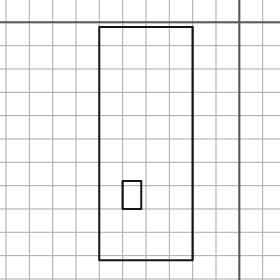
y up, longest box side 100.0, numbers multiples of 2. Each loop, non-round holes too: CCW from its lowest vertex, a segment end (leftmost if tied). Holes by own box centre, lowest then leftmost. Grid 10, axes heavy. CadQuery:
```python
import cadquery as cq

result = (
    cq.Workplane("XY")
    .moveTo(-60.0, -102.0)
    .lineTo(-20.0, -102.0)
    .lineTo(-20.0, -2.0)
    .lineTo(-60.0, -2.0)
    .close()
    .moveTo(-50.0, -80.0)
    .lineTo(-42.0, -80.0)
    .lineTo(-42.0, -68.0)
    .lineTo(-50.0, -68.0)
    .close()
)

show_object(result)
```